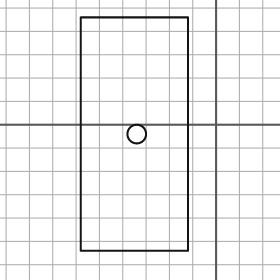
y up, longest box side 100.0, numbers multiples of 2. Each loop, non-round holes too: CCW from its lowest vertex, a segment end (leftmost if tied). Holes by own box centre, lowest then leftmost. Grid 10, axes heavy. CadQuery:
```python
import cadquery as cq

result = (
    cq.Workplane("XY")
    .moveTo(-58.0, -54.0)
    .lineTo(-12.0, -54.0)
    .lineTo(-12.0, 46.0)
    .lineTo(-58.0, 46.0)
    .close()
    .moveTo(-34.0, -4.0)
    .circle(4.0)
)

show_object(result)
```